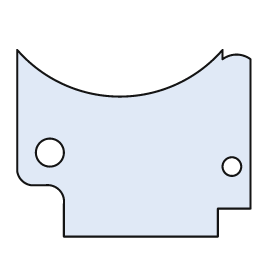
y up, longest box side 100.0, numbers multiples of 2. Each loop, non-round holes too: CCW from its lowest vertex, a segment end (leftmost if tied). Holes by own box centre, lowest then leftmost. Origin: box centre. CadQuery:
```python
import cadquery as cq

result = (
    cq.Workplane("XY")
    .moveTo(-30.0, -40.0)
    .lineTo(36.0, -40.0)
    .lineTo(36.0, -28.0)
    .lineTo(50.0, -28.0)
    .lineTo(50.0, 36.0)
    .threePointArc((44.0, 38.0), (38.0, 36.0))
    .lineTo(38.0, 40.0)
    .threePointArc((-6.0, 20.0), (-50.0, 40.0))
    .lineTo(-50.0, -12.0)
    .threePointArc((-48.0, -16.0), (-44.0, -18.0))
    .lineTo(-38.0, -18.0)
    .threePointArc((-32.0, -20.0), (-30.0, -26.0))
    .close()
    .moveTo(42.0, -10.0)
    .circle(4.0)
    .moveTo(-36.0, -4.0)
    .circle(6.0)
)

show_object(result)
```